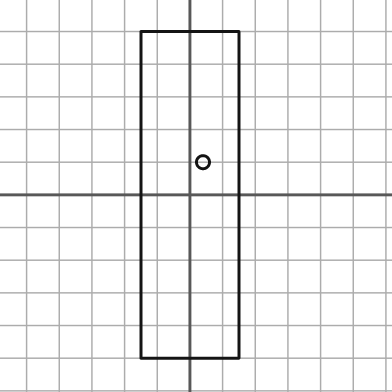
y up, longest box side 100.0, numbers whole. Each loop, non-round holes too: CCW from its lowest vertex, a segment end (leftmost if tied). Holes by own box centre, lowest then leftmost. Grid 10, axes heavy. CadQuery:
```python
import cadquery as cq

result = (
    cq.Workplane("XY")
    .moveTo(-15.0, -50.0)
    .lineTo(15.0, -50.0)
    .lineTo(15.0, 50.0)
    .lineTo(-15.0, 50.0)
    .close()
    .moveTo(4.0, 10.0)
    .circle(2.0)
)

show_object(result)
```